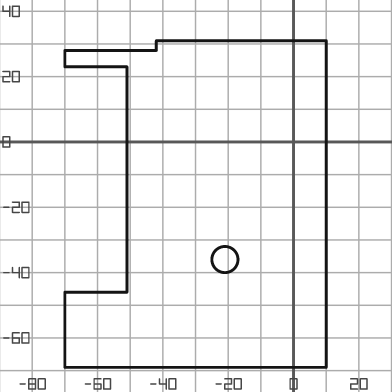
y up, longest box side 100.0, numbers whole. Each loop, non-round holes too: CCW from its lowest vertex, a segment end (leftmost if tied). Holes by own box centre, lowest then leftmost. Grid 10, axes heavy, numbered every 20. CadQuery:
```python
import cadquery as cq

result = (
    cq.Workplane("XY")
    .moveTo(-70.0, -69.0)
    .lineTo(10.0, -69.0)
    .lineTo(10.0, 31.0)
    .lineTo(-42.0, 31.0)
    .lineTo(-42.0, 28.0)
    .lineTo(-70.0, 28.0)
    .lineTo(-70.0, 23.0)
    .lineTo(-51.0, 23.0)
    .lineTo(-51.0, -46.0)
    .lineTo(-70.0, -46.0)
    .close()
    .moveTo(-21.0, -36.0)
    .circle(4.0)
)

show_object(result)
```